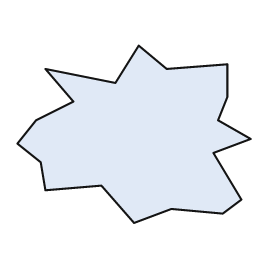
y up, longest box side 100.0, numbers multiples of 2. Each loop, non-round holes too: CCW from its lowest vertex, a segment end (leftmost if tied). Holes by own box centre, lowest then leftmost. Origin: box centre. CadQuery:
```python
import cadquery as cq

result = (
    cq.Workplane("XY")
    .moveTo(0.0, -38.0)
    .lineTo(16.0, -32.0)
    .lineTo(38.0, -34.0)
    .lineTo(46.0, -28.0)
    .lineTo(34.0, -8.0)
    .lineTo(50.0, -2.0)
    .lineTo(36.0, 6.0)
    .lineTo(40.0, 16.0)
    .lineTo(40.0, 30.0)
    .lineTo(14.0, 28.0)
    .lineTo(2.0, 38.0)
    .lineTo(-8.0, 22.0)
    .lineTo(-38.0, 28.0)
    .lineTo(-26.0, 14.0)
    .lineTo(-42.0, 6.0)
    .lineTo(-50.0, -4.0)
    .lineTo(-40.0, -12.0)
    .lineTo(-38.0, -24.0)
    .lineTo(-14.0, -22.0)
    .close()
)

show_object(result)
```